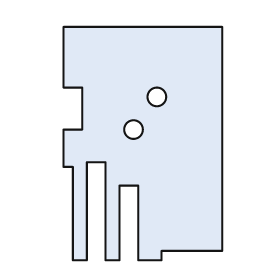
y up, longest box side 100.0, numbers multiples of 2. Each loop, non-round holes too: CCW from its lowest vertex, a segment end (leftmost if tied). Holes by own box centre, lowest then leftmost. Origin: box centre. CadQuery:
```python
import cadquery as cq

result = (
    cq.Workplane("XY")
    .moveTo(-30.0, -50.0)
    .lineTo(-24.0, -50.0)
    .lineTo(-24.0, -8.0)
    .lineTo(-16.0, -8.0)
    .lineTo(-16.0, -50.0)
    .lineTo(-10.0, -50.0)
    .lineTo(-10.0, -18.0)
    .lineTo(-2.0, -18.0)
    .lineTo(-2.0, -50.0)
    .lineTo(8.0, -50.0)
    .lineTo(8.0, -46.0)
    .lineTo(34.0, -46.0)
    .lineTo(34.0, 50.0)
    .lineTo(-34.0, 50.0)
    .lineTo(-34.0, 24.0)
    .lineTo(-26.0, 24.0)
    .lineTo(-26.0, 6.0)
    .lineTo(-34.0, 6.0)
    .lineTo(-34.0, -10.0)
    .lineTo(-30.0, -10.0)
    .close()
    .moveTo(-4.0, 6.0)
    .circle(4.0)
    .moveTo(6.0, 20.0)
    .circle(4.0)
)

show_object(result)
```